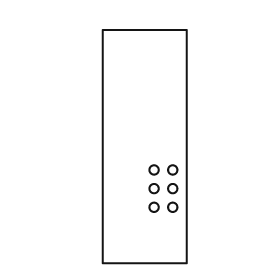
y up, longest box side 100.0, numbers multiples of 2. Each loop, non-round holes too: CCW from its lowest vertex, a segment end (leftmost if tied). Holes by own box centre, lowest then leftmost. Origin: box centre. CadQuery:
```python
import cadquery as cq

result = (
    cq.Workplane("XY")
    .moveTo(-18.0, -50.0)
    .lineTo(18.0, -50.0)
    .lineTo(18.0, 50.0)
    .lineTo(-18.0, 50.0)
    .close()
    .moveTo(4.0, -26.0)
    .circle(2.0)
    .moveTo(12.0, -26.0)
    .circle(2.0)
    .moveTo(4.0, -18.0)
    .circle(2.0)
    .moveTo(12.0, -18.0)
    .circle(2.0)
    .moveTo(4.0, -10.0)
    .circle(2.0)
    .moveTo(12.0, -10.0)
    .circle(2.0)
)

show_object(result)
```